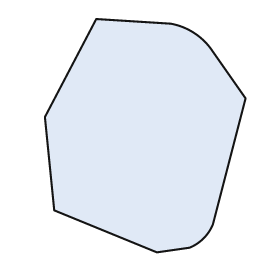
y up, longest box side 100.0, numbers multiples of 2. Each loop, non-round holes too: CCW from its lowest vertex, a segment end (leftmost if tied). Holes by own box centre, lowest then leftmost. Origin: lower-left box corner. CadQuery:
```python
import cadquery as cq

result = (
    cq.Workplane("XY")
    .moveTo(48.0, 0.0)
    .lineTo(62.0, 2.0)
    .threePointArc((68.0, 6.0), (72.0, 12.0))
    .lineTo(86.0, 66.0)
    .lineTo(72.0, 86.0)
    .threePointArc((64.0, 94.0), (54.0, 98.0))
    .lineTo(22.0, 100.0)
    .lineTo(0.0, 58.0)
    .lineTo(4.0, 18.0)
    .close()
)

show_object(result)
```